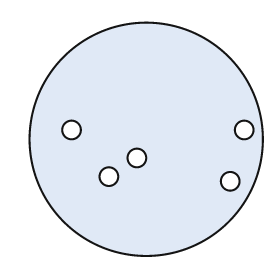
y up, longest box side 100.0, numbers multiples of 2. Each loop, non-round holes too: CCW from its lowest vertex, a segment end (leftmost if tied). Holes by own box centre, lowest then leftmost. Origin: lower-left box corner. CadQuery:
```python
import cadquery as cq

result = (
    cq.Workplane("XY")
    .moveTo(50.0, 50.0)
    .circle(50.0)
    .moveTo(86.0, 32.0)
    .circle(4.0)
    .moveTo(34.0, 34.0)
    .circle(4.0)
    .moveTo(46.0, 42.0)
    .circle(4.0)
    .moveTo(18.0, 54.0)
    .circle(4.0)
    .moveTo(92.0, 54.0)
    .circle(4.0)
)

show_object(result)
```